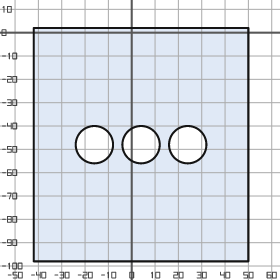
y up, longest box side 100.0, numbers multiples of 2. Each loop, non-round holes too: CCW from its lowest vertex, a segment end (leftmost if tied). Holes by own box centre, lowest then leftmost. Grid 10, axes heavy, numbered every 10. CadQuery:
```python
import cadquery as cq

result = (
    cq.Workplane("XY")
    .moveTo(-42.0, -98.0)
    .lineTo(50.0, -98.0)
    .lineTo(50.0, 2.0)
    .lineTo(-42.0, 2.0)
    .close()
    .moveTo(-16.0, -48.0)
    .circle(8.0)
    .moveTo(4.0, -48.0)
    .circle(8.0)
    .moveTo(24.0, -48.0)
    .circle(8.0)
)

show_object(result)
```